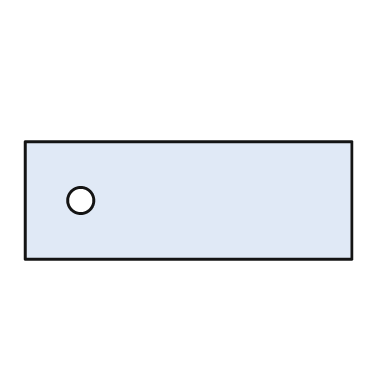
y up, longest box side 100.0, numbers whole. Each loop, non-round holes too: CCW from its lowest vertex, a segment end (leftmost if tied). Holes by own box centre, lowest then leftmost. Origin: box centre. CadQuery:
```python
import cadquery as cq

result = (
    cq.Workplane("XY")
    .moveTo(-50.0, -18.0)
    .lineTo(50.0, -18.0)
    .lineTo(50.0, 18.0)
    .lineTo(-50.0, 18.0)
    .close()
    .moveTo(-33.0, 0.0)
    .circle(4.0)
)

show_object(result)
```